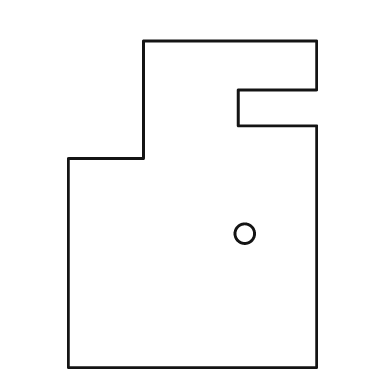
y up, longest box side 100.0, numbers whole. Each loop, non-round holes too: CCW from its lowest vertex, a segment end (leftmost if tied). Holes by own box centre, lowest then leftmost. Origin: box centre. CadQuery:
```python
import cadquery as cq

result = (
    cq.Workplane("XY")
    .moveTo(-38.0, -50.0)
    .lineTo(38.0, -50.0)
    .lineTo(38.0, 24.0)
    .lineTo(14.0, 24.0)
    .lineTo(14.0, 35.0)
    .lineTo(38.0, 35.0)
    .lineTo(38.0, 50.0)
    .lineTo(-15.0, 50.0)
    .lineTo(-15.0, 14.0)
    .lineTo(-38.0, 14.0)
    .close()
    .moveTo(16.0, -9.0)
    .circle(3.0)
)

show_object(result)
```